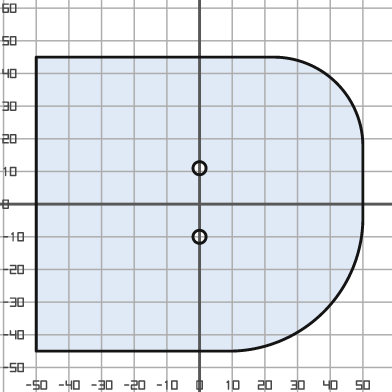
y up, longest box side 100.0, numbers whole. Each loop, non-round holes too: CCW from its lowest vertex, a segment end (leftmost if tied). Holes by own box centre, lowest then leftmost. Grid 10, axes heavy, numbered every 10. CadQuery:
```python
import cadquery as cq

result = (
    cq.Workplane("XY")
    .moveTo(-50.0, -45.0)
    .lineTo(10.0, -45.0)
    .threePointArc((38.0, -33.0), (50.0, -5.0))
    .lineTo(50.0, 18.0)
    .threePointArc((42.0, 37.0), (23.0, 45.0))
    .lineTo(-50.0, 45.0)
    .close()
    .moveTo(0.0, -10.0)
    .circle(2.0)
    .moveTo(0.0, 11.0)
    .circle(2.0)
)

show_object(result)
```